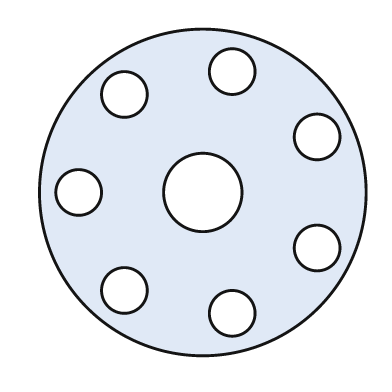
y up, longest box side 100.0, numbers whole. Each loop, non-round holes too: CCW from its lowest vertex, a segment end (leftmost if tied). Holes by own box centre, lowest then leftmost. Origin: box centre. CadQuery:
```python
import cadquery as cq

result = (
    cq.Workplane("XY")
    .moveTo(0.0, 0.0)
    .circle(50.0)
    .moveTo(9.0, -37.0)
    .circle(7.0)
    .moveTo(-24.0, -30.0)
    .circle(7.0)
    .moveTo(35.0, -17.0)
    .circle(7.0)
    .moveTo(-38.0, 0.0)
    .circle(7.0)
    .moveTo(0.0, 0.0)
    .circle(12.0)
    .moveTo(35.0, 17.0)
    .circle(7.0)
    .moveTo(-24.0, 30.0)
    .circle(7.0)
    .moveTo(9.0, 37.0)
    .circle(7.0)
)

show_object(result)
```